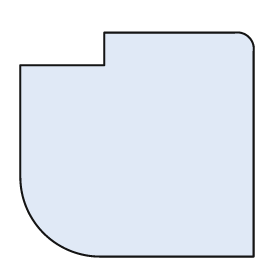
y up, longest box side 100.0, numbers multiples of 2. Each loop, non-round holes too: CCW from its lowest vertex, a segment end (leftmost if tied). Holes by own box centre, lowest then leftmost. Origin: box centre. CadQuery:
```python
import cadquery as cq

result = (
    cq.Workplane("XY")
    .moveTo(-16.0, -48.0)
    .lineTo(50.0, -48.0)
    .lineTo(50.0, 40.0)
    .threePointArc((48.0, 46.0), (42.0, 48.0))
    .lineTo(-14.0, 48.0)
    .lineTo(-14.0, 34.0)
    .lineTo(-50.0, 34.0)
    .lineTo(-50.0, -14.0)
    .threePointArc((-40.0, -38.0), (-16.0, -48.0))
    .close()
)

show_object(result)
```